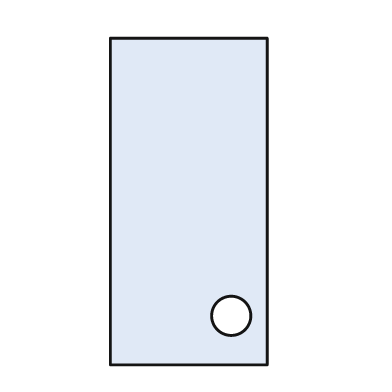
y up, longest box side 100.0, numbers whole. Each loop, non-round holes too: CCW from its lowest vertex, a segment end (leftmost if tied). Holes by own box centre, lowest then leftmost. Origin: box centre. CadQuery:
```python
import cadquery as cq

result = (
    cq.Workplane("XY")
    .moveTo(-24.0, -50.0)
    .lineTo(24.0, -50.0)
    .lineTo(24.0, 50.0)
    .lineTo(-24.0, 50.0)
    .close()
    .moveTo(13.0, -35.0)
    .circle(6.0)
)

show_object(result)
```